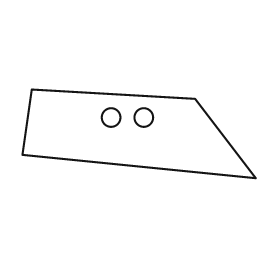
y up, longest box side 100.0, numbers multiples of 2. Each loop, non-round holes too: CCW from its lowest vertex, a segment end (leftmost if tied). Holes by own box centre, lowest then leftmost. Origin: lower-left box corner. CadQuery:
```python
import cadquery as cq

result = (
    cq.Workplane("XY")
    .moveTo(100.0, 0.0)
    .lineTo(74.0, 34.0)
    .lineTo(4.0, 38.0)
    .lineTo(0.0, 10.0)
    .close()
    .moveTo(38.0, 26.0)
    .circle(4.0)
    .moveTo(52.0, 26.0)
    .circle(4.0)
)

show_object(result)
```